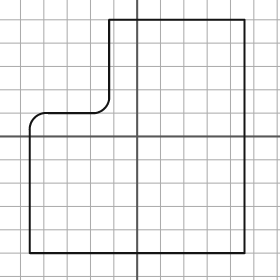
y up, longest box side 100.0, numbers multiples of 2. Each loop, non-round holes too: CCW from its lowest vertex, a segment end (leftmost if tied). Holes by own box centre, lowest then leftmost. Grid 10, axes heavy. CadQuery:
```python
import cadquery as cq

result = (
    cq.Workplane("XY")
    .moveTo(-46.0, -50.0)
    .lineTo(46.0, -50.0)
    .lineTo(46.0, 50.0)
    .lineTo(-12.0, 50.0)
    .lineTo(-12.0, 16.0)
    .threePointArc((-14.0, 12.0), (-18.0, 10.0))
    .lineTo(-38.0, 10.0)
    .threePointArc((-44.0, 8.0), (-46.0, 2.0))
    .close()
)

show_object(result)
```